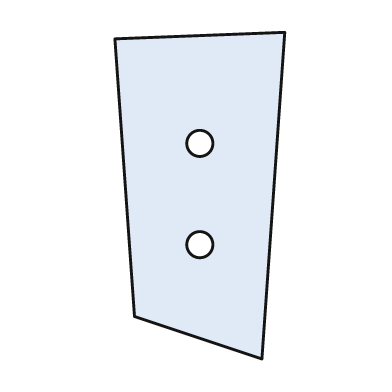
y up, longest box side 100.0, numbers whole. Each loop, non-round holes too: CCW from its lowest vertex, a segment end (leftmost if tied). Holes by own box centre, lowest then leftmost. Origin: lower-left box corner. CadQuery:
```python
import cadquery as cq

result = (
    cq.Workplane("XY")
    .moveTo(45.0, 0.0)
    .lineTo(52.0, 100.0)
    .lineTo(0.0, 98.0)
    .lineTo(6.0, 13.0)
    .close()
    .moveTo(26.0, 35.0)
    .circle(4.0)
    .moveTo(26.0, 66.0)
    .circle(4.0)
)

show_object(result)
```